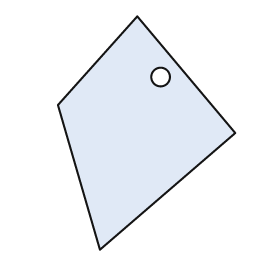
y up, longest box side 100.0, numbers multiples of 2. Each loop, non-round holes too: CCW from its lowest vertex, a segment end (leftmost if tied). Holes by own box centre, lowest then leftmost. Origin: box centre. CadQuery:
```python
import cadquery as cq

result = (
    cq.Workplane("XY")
    .moveTo(-20.0, -50.0)
    .lineTo(38.0, 0.0)
    .lineTo(-4.0, 50.0)
    .lineTo(-38.0, 12.0)
    .close()
    .moveTo(6.0, 24.0)
    .circle(4.0)
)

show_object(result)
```